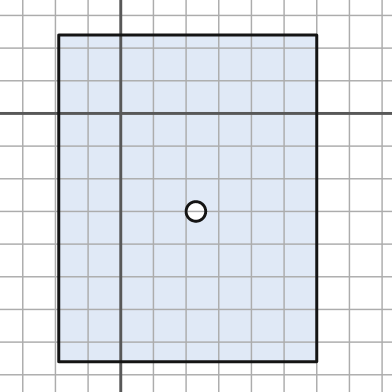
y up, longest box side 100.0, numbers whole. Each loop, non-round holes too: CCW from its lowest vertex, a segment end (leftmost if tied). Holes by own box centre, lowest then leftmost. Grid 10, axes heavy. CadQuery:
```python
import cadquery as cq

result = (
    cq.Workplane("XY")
    .moveTo(-19.0, -76.0)
    .lineTo(60.0, -76.0)
    .lineTo(60.0, 24.0)
    .lineTo(-19.0, 24.0)
    .close()
    .moveTo(23.0, -30.0)
    .circle(3.0)
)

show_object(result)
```